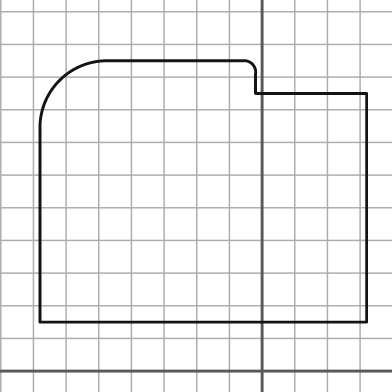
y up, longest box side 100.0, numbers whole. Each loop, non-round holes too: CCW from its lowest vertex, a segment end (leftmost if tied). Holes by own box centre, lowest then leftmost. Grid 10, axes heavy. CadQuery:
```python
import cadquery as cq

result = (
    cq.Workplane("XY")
    .moveTo(-68.0, 15.0)
    .lineTo(32.0, 15.0)
    .lineTo(32.0, 85.0)
    .lineTo(-2.0, 85.0)
    .lineTo(-2.0, 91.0)
    .threePointArc((-3.0, 94.0), (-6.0, 95.0))
    .lineTo(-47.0, 95.0)
    .threePointArc((-62.0, 89.0), (-68.0, 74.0))
    .close()
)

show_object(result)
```